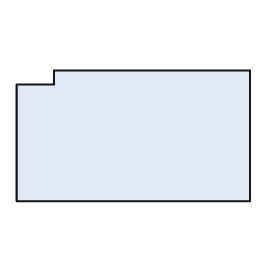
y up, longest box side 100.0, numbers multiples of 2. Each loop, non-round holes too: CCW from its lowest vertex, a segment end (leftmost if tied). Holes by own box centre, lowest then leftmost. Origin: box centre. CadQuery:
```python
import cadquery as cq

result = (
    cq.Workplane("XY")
    .moveTo(-50.0, -28.0)
    .lineTo(50.0, -28.0)
    .lineTo(50.0, 28.0)
    .lineTo(-34.0, 28.0)
    .lineTo(-34.0, 22.0)
    .lineTo(-50.0, 22.0)
    .close()
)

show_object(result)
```